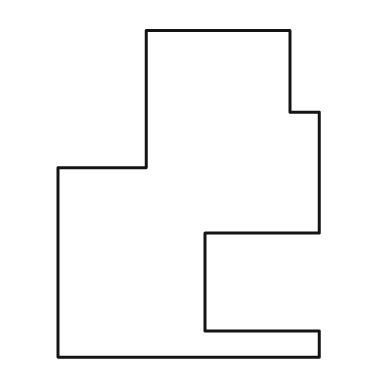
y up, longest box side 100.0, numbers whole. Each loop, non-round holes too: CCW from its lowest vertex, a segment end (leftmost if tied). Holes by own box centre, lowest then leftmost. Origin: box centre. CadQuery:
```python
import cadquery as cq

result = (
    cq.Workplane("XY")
    .moveTo(-40.0, -50.0)
    .lineTo(40.0, -50.0)
    .lineTo(40.0, -42.0)
    .lineTo(5.0, -42.0)
    .lineTo(5.0, -12.0)
    .lineTo(40.0, -12.0)
    .lineTo(40.0, 25.0)
    .lineTo(31.0, 25.0)
    .lineTo(31.0, 50.0)
    .lineTo(-13.0, 50.0)
    .lineTo(-13.0, 8.0)
    .lineTo(-40.0, 8.0)
    .close()
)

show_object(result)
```